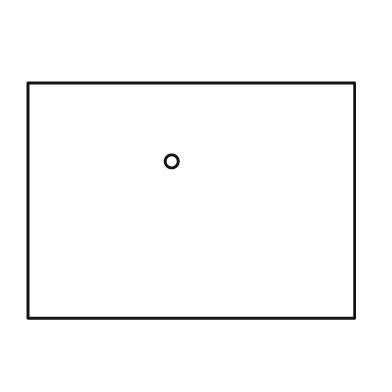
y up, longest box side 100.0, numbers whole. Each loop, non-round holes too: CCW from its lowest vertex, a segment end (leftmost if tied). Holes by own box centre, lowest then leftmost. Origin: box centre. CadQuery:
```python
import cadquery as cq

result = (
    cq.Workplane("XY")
    .moveTo(-50.0, -36.0)
    .lineTo(50.0, -36.0)
    .lineTo(50.0, 36.0)
    .lineTo(-50.0, 36.0)
    .close()
    .moveTo(-6.0, 12.0)
    .circle(2.0)
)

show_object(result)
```